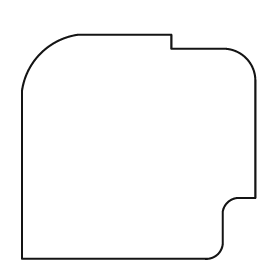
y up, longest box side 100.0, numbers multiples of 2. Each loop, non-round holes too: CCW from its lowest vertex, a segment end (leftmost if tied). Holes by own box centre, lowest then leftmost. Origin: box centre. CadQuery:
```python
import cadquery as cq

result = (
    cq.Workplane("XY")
    .moveTo(-50.0, -48.0)
    .lineTo(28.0, -48.0)
    .threePointArc((34.0, -46.0), (36.0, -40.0))
    .lineTo(36.0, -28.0)
    .threePointArc((38.0, -24.0), (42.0, -22.0))
    .lineTo(50.0, -22.0)
    .lineTo(50.0, 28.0)
    .threePointArc((46.0, 38.0), (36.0, 42.0))
    .lineTo(14.0, 42.0)
    .lineTo(14.0, 48.0)
    .lineTo(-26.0, 48.0)
    .threePointArc((-42.0, 40.0), (-50.0, 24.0))
    .close()
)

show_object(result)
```